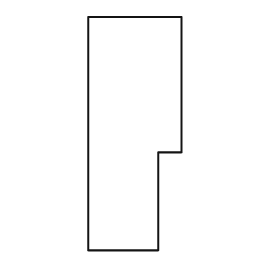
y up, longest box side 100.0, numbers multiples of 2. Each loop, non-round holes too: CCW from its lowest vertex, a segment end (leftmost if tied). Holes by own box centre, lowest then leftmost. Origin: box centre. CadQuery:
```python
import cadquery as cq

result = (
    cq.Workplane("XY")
    .moveTo(-20.0, -50.0)
    .lineTo(10.0, -50.0)
    .lineTo(10.0, -8.0)
    .lineTo(20.0, -8.0)
    .lineTo(20.0, 50.0)
    .lineTo(-20.0, 50.0)
    .close()
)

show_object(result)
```